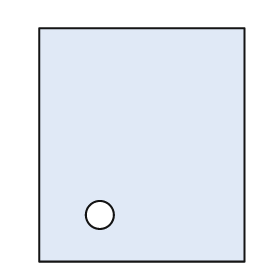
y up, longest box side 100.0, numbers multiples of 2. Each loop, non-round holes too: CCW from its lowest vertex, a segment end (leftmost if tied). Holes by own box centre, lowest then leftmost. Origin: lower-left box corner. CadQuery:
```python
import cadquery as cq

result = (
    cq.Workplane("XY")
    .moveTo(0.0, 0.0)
    .lineTo(88.0, 0.0)
    .lineTo(88.0, 100.0)
    .lineTo(0.0, 100.0)
    .close()
    .moveTo(26.0, 20.0)
    .circle(6.0)
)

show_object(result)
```